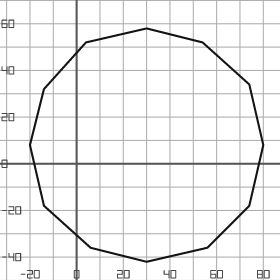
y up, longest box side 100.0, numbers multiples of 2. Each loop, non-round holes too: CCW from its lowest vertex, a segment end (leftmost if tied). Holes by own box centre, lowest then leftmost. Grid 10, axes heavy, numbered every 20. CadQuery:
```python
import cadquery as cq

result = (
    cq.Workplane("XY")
    .moveTo(30.0, -42.0)
    .lineTo(56.0, -36.0)
    .lineTo(74.0, -18.0)
    .lineTo(80.0, 8.0)
    .lineTo(74.0, 34.0)
    .lineTo(54.0, 52.0)
    .lineTo(30.0, 58.0)
    .lineTo(4.0, 52.0)
    .lineTo(-14.0, 32.0)
    .lineTo(-20.0, 8.0)
    .lineTo(-14.0, -18.0)
    .lineTo(6.0, -36.0)
    .close()
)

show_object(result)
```